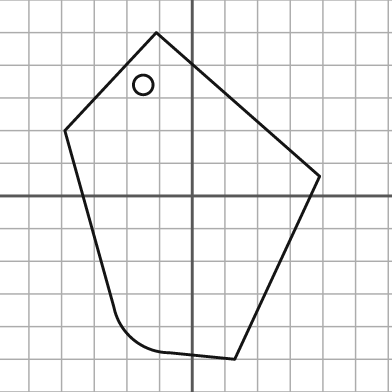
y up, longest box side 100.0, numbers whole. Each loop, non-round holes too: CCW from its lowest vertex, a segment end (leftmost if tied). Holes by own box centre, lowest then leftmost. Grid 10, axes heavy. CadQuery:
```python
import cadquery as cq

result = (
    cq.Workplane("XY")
    .moveTo(13.0, -50.0)
    .lineTo(39.0, 6.0)
    .lineTo(-11.0, 50.0)
    .lineTo(-39.0, 20.0)
    .lineTo(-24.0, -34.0)
    .threePointArc((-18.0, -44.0), (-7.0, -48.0))
    .close()
    .moveTo(-15.0, 34.0)
    .circle(3.0)
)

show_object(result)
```